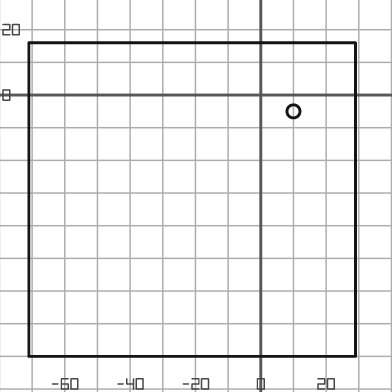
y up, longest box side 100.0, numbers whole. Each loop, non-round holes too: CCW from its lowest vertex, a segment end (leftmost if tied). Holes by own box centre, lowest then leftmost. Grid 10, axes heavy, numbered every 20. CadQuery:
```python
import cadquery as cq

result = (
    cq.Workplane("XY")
    .moveTo(-71.0, -80.0)
    .lineTo(29.0, -80.0)
    .lineTo(29.0, 16.0)
    .lineTo(-71.0, 16.0)
    .close()
    .moveTo(10.0, -5.0)
    .circle(2.0)
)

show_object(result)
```